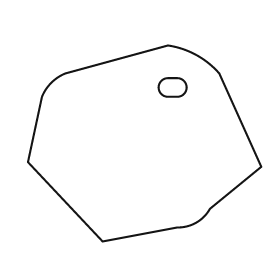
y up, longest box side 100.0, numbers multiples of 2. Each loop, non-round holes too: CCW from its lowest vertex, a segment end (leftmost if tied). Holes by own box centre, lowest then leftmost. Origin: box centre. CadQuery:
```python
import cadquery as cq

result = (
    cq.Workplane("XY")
    .moveTo(-18.0, -42.0)
    .lineTo(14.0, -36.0)
    .threePointArc((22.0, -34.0), (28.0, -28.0))
    .lineTo(50.0, -10.0)
    .lineTo(32.0, 30.0)
    .threePointArc((22.0, 38.0), (10.0, 42.0))
    .lineTo(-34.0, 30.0)
    .threePointArc((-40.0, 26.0), (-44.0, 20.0))
    .lineTo(-50.0, -8.0)
    .close()
    .moveTo(10.0, 20.0)
    .lineTo(14.0, 20.0)
    .threePointArc((18.0, 24.0), (14.0, 28.0))
    .lineTo(10.0, 28.0)
    .threePointArc((6.0, 24.0), (10.0, 20.0))
    .close()
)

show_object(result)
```